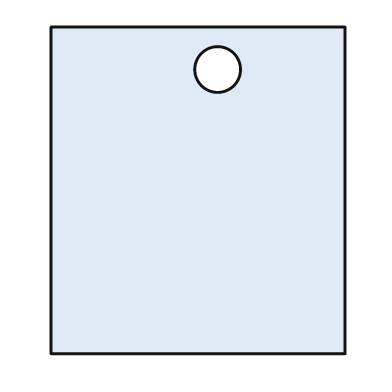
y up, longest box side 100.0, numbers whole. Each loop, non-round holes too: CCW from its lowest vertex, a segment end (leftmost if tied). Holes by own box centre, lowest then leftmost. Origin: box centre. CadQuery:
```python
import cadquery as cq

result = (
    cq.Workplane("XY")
    .moveTo(-45.0, -50.0)
    .lineTo(45.0, -50.0)
    .lineTo(45.0, 50.0)
    .lineTo(-45.0, 50.0)
    .close()
    .moveTo(6.0, 37.0)
    .circle(7.0)
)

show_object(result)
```